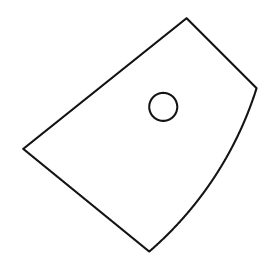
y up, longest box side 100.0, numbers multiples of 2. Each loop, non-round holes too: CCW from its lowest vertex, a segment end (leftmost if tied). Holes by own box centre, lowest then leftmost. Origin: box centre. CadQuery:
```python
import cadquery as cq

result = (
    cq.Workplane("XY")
    .moveTo(4.0, -50.0)
    .threePointArc((32.0, -18.0), (50.0, 20.0))
    .lineTo(20.0, 50.0)
    .lineTo(-50.0, -6.0)
    .close()
    .moveTo(10.0, 12.0)
    .circle(6.0)
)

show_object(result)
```